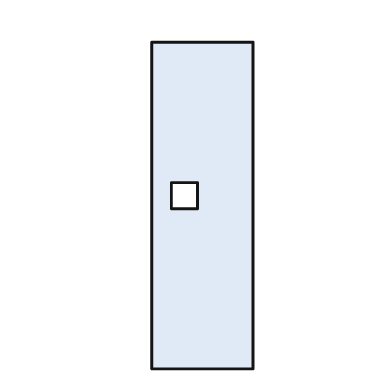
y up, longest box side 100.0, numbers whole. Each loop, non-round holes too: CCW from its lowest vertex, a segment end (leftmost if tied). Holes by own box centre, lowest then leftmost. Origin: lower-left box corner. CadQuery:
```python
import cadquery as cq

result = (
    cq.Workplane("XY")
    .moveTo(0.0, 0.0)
    .lineTo(31.0, 0.0)
    .lineTo(31.0, 100.0)
    .lineTo(0.0, 100.0)
    .close()
    .moveTo(6.0, 49.0)
    .lineTo(14.0, 49.0)
    .lineTo(14.0, 57.0)
    .lineTo(6.0, 57.0)
    .close()
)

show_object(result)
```